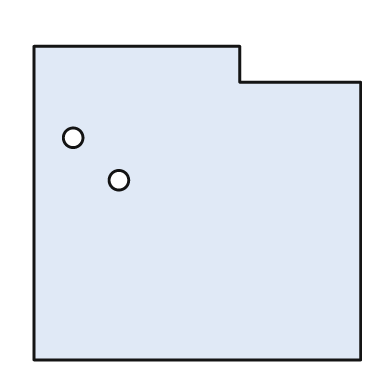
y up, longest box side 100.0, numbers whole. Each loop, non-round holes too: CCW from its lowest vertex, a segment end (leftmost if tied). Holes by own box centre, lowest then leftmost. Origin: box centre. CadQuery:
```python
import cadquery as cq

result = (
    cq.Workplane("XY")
    .moveTo(-50.0, -48.0)
    .lineTo(50.0, -48.0)
    .lineTo(50.0, 37.0)
    .lineTo(13.0, 37.0)
    .lineTo(13.0, 48.0)
    .lineTo(-50.0, 48.0)
    .close()
    .moveTo(-24.0, 7.0)
    .circle(3.0)
    .moveTo(-38.0, 20.0)
    .circle(3.0)
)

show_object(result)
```